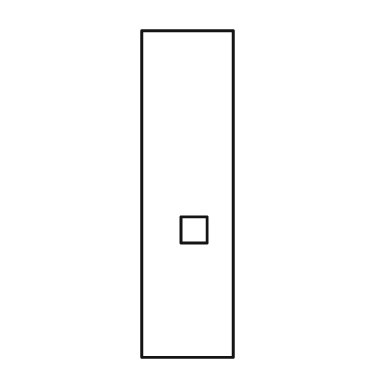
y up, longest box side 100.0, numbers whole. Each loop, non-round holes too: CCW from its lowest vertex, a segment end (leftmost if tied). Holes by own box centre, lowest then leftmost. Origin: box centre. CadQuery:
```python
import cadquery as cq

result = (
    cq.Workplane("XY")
    .moveTo(-14.0, -50.0)
    .lineTo(14.0, -50.0)
    .lineTo(14.0, 50.0)
    .lineTo(-14.0, 50.0)
    .close()
    .moveTo(-2.0, -15.0)
    .lineTo(6.0, -15.0)
    .lineTo(6.0, -7.0)
    .lineTo(-2.0, -7.0)
    .close()
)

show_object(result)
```